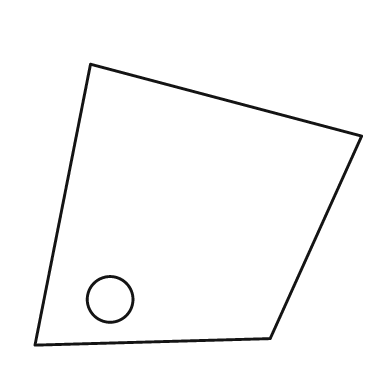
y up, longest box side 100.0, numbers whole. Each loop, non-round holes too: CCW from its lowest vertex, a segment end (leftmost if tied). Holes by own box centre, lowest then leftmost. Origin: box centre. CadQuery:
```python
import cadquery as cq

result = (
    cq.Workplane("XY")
    .moveTo(-50.0, -43.0)
    .lineTo(22.0, -41.0)
    .lineTo(50.0, 21.0)
    .lineTo(-33.0, 43.0)
    .close()
    .moveTo(-27.0, -29.0)
    .circle(7.0)
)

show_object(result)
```